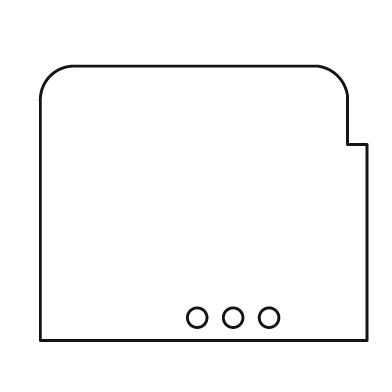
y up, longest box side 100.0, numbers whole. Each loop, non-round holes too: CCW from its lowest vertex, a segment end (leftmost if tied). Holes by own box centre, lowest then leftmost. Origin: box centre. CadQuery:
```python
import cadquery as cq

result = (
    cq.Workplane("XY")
    .moveTo(-50.0, -42.0)
    .lineTo(50.0, -42.0)
    .lineTo(50.0, 18.0)
    .lineTo(44.0, 18.0)
    .lineTo(44.0, 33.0)
    .threePointArc((41.0, 39.0), (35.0, 42.0))
    .lineTo(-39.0, 42.0)
    .threePointArc((-47.0, 39.0), (-50.0, 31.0))
    .close()
    .moveTo(-2.0, -35.0)
    .circle(3.0)
    .moveTo(9.0, -35.0)
    .circle(3.0)
    .moveTo(20.0, -35.0)
    .circle(3.0)
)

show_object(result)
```